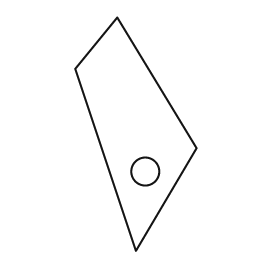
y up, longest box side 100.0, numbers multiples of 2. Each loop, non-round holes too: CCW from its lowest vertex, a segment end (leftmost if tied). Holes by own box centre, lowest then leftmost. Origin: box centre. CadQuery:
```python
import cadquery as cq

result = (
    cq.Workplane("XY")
    .moveTo(0.0, -50.0)
    .lineTo(26.0, -6.0)
    .lineTo(-8.0, 50.0)
    .lineTo(-26.0, 28.0)
    .close()
    .moveTo(4.0, -16.0)
    .circle(6.0)
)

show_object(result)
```